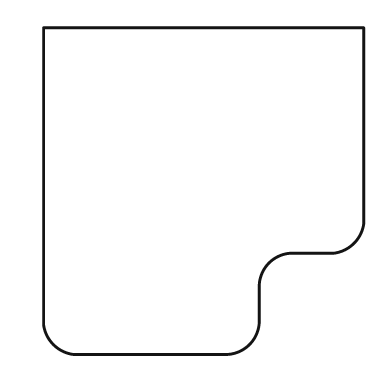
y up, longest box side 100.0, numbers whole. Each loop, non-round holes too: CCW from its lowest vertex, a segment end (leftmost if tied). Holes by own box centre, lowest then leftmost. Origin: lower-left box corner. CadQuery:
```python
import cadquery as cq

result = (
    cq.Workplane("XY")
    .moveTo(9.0, 0.0)
    .lineTo(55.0, 0.0)
    .threePointArc((63.0, 3.0), (66.0, 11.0))
    .lineTo(66.0, 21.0)
    .threePointArc((69.0, 28.0), (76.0, 31.0))
    .lineTo(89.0, 31.0)
    .threePointArc((95.0, 34.0), (98.0, 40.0))
    .lineTo(98.0, 100.0)
    .lineTo(0.0, 100.0)
    .lineTo(0.0, 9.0)
    .threePointArc((3.0, 3.0), (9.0, 0.0))
    .close()
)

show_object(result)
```